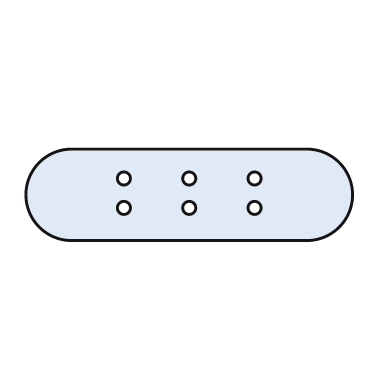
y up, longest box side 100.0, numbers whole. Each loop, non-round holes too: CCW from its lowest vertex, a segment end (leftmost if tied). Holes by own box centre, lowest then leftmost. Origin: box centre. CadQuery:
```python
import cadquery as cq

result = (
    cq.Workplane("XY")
    .moveTo(-36.0, -14.0)
    .lineTo(36.0, -14.0)
    .threePointArc((50.0, 0.0), (36.0, 14.0))
    .lineTo(-36.0, 14.0)
    .threePointArc((-50.0, 0.0), (-36.0, -14.0))
    .close()
    .moveTo(-20.0, -4.0)
    .circle(2.0)
    .moveTo(0.0, -4.0)
    .circle(2.0)
    .moveTo(20.0, -4.0)
    .circle(2.0)
    .moveTo(-20.0, 5.0)
    .circle(2.0)
    .moveTo(0.0, 5.0)
    .circle(2.0)
    .moveTo(20.0, 5.0)
    .circle(2.0)
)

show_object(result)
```